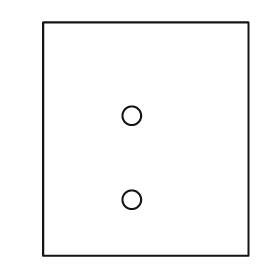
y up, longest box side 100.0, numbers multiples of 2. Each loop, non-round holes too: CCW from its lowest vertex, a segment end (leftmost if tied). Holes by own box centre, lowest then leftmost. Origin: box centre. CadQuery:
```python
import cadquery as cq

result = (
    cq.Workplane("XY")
    .moveTo(-44.0, -50.0)
    .lineTo(44.0, -50.0)
    .lineTo(44.0, 50.0)
    .lineTo(-44.0, 50.0)
    .close()
    .moveTo(-6.0, -26.0)
    .circle(4.0)
    .moveTo(-6.0, 10.0)
    .circle(4.0)
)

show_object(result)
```